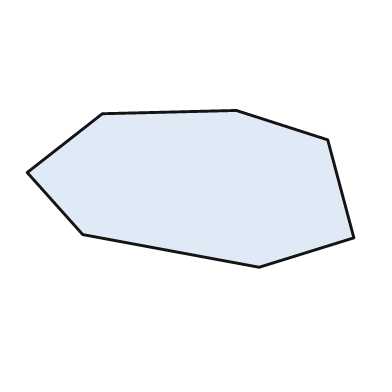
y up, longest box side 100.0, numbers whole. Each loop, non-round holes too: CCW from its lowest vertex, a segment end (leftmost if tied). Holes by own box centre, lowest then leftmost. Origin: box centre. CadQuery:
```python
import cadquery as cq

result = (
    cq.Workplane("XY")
    .moveTo(21.0, -24.0)
    .lineTo(50.0, -15.0)
    .lineTo(42.0, 15.0)
    .lineTo(14.0, 24.0)
    .lineTo(-27.0, 23.0)
    .lineTo(-50.0, 5.0)
    .lineTo(-33.0, -14.0)
    .close()
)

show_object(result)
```